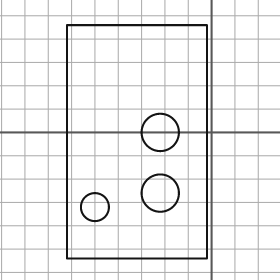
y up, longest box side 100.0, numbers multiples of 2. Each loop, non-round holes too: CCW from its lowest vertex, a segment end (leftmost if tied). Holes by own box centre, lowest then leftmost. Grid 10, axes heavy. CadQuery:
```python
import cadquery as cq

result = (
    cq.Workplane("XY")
    .moveTo(-62.0, -54.0)
    .lineTo(-2.0, -54.0)
    .lineTo(-2.0, 46.0)
    .lineTo(-62.0, 46.0)
    .close()
    .moveTo(-50.0, -32.0)
    .circle(6.0)
    .moveTo(-22.0, -26.0)
    .circle(8.0)
    .moveTo(-22.0, 0.0)
    .circle(8.0)
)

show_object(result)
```